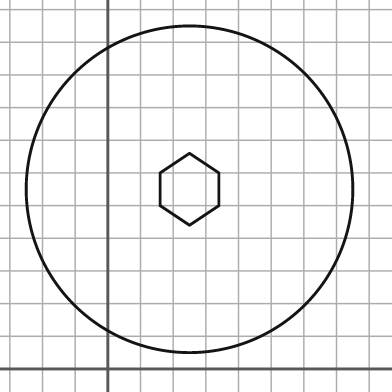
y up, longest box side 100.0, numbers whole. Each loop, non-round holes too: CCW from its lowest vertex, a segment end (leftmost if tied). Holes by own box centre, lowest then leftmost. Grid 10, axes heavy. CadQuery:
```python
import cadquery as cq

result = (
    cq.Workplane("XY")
    .moveTo(25.0, 55.0)
    .circle(50.0)
    .moveTo(25.0, 44.0)
    .lineTo(34.0, 50.0)
    .lineTo(34.0, 60.0)
    .lineTo(25.0, 66.0)
    .lineTo(16.0, 60.0)
    .lineTo(16.0, 50.0)
    .close()
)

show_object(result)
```